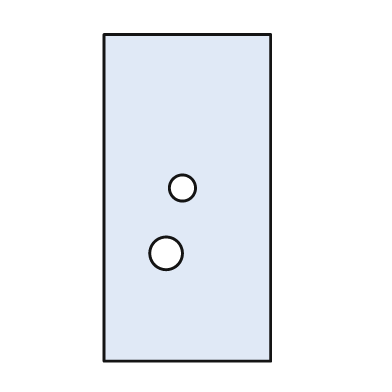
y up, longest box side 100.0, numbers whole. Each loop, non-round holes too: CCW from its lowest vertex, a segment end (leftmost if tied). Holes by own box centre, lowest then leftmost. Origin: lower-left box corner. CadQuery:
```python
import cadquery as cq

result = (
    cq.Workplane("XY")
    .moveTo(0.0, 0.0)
    .lineTo(51.0, 0.0)
    .lineTo(51.0, 100.0)
    .lineTo(0.0, 100.0)
    .close()
    .moveTo(19.0, 33.0)
    .circle(5.0)
    .moveTo(24.0, 53.0)
    .circle(4.0)
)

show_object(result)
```